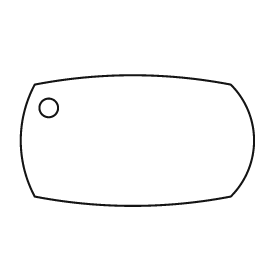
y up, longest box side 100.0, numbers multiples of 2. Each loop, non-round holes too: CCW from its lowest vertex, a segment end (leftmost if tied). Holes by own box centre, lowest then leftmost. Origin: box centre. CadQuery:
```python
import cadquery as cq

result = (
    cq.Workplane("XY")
    .moveTo(-44.0, -24.0)
    .threePointArc((-2.0, -28.0), (40.0, -24.0))
    .threePointArc((50.0, 0.0), (40.0, 24.0))
    .threePointArc((-2.0, 28.0), (-44.0, 24.0))
    .threePointArc((-50.0, 0.0), (-44.0, -24.0))
    .close()
    .moveTo(-38.0, 14.0)
    .circle(4.0)
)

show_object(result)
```